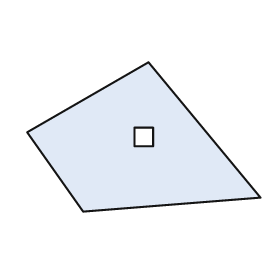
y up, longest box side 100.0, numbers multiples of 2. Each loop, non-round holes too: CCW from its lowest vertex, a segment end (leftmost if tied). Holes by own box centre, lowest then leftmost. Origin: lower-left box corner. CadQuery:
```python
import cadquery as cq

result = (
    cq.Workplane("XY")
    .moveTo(24.0, 0.0)
    .lineTo(100.0, 6.0)
    .lineTo(52.0, 64.0)
    .lineTo(0.0, 34.0)
    .close()
    .moveTo(46.0, 28.0)
    .lineTo(54.0, 28.0)
    .lineTo(54.0, 36.0)
    .lineTo(46.0, 36.0)
    .close()
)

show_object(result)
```